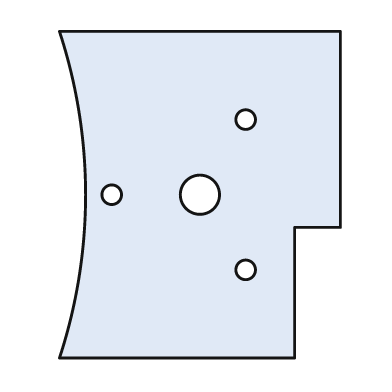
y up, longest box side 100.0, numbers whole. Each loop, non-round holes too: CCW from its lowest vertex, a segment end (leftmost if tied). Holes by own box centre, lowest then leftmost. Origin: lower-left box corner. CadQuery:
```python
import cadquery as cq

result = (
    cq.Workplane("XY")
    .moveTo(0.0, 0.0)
    .lineTo(72.0, 0.0)
    .lineTo(72.0, 40.0)
    .lineTo(86.0, 40.0)
    .lineTo(86.0, 100.0)
    .lineTo(0.0, 100.0)
    .threePointArc((8.0, 50.0), (0.0, 0.0))
    .close()
    .moveTo(57.0, 27.0)
    .circle(3.0)
    .moveTo(16.0, 50.0)
    .circle(3.0)
    .moveTo(43.0, 50.0)
    .circle(6.0)
    .moveTo(57.0, 73.0)
    .circle(3.0)
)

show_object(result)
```